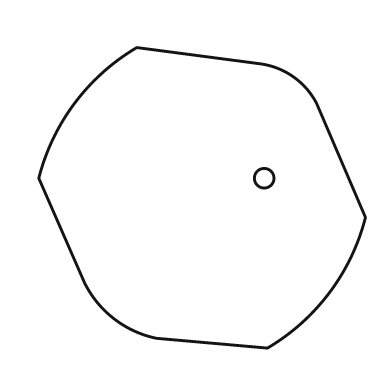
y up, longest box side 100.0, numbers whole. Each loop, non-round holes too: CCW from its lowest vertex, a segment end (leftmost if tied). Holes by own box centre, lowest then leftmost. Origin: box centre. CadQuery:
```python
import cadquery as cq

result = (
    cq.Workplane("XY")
    .moveTo(20.0, -46.0)
    .threePointArc((39.0, -29.0), (50.0, -6.0))
    .lineTo(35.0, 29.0)
    .threePointArc((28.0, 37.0), (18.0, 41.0))
    .lineTo(-20.0, 46.0)
    .threePointArc((-39.0, 29.0), (-50.0, 6.0))
    .lineTo(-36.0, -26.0)
    .threePointArc((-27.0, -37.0), (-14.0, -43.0))
    .close()
    .moveTo(19.0, 6.0)
    .circle(3.0)
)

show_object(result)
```